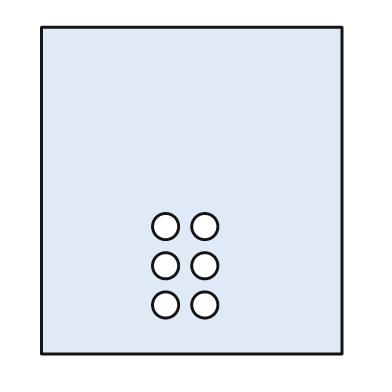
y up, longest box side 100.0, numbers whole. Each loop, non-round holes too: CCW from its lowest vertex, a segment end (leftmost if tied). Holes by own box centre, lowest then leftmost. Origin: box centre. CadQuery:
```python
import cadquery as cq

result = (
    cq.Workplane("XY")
    .moveTo(-46.0, -50.0)
    .lineTo(46.0, -50.0)
    .lineTo(46.0, 50.0)
    .lineTo(-46.0, 50.0)
    .close()
    .moveTo(-8.0, -35.0)
    .circle(4.0)
    .moveTo(4.0, -35.0)
    .circle(4.0)
    .moveTo(-8.0, -23.0)
    .circle(4.0)
    .moveTo(4.0, -23.0)
    .circle(4.0)
    .moveTo(-8.0, -11.0)
    .circle(4.0)
    .moveTo(4.0, -11.0)
    .circle(4.0)
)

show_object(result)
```